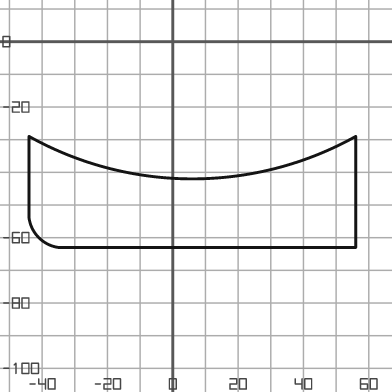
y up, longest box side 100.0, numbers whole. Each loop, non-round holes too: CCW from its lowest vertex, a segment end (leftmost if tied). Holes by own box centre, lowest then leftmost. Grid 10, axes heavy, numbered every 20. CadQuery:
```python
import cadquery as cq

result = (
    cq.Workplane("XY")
    .moveTo(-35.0, -63.0)
    .lineTo(56.0, -63.0)
    .lineTo(56.0, -29.0)
    .threePointArc((6.0, -42.0), (-44.0, -29.0))
    .lineTo(-44.0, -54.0)
    .threePointArc((-41.0, -60.0), (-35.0, -63.0))
    .close()
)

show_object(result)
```